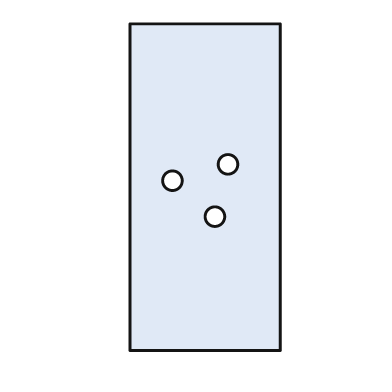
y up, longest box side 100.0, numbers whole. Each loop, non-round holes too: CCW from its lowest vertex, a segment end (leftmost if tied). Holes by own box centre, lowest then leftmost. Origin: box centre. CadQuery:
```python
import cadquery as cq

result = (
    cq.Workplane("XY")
    .moveTo(-23.0, -50.0)
    .lineTo(23.0, -50.0)
    .lineTo(23.0, 50.0)
    .lineTo(-23.0, 50.0)
    .close()
    .moveTo(3.0, -9.0)
    .circle(3.0)
    .moveTo(-10.0, 2.0)
    .circle(3.0)
    .moveTo(7.0, 7.0)
    .circle(3.0)
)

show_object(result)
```